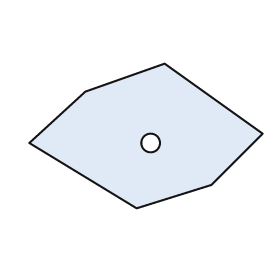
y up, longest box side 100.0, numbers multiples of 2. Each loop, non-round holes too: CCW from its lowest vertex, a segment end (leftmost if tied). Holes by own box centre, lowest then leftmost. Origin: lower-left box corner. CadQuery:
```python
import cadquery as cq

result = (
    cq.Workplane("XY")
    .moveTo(46.0, 0.0)
    .lineTo(78.0, 10.0)
    .lineTo(100.0, 32.0)
    .lineTo(58.0, 62.0)
    .lineTo(24.0, 50.0)
    .lineTo(0.0, 28.0)
    .close()
    .moveTo(52.0, 28.0)
    .circle(4.0)
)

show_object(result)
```